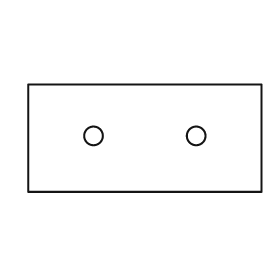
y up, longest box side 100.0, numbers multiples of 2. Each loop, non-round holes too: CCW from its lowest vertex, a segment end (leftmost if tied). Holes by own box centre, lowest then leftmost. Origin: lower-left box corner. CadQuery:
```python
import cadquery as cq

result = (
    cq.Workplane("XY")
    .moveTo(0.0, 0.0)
    .lineTo(100.0, 0.0)
    .lineTo(100.0, 46.0)
    .lineTo(0.0, 46.0)
    .close()
    .moveTo(28.0, 24.0)
    .circle(4.0)
    .moveTo(72.0, 24.0)
    .circle(4.0)
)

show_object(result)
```